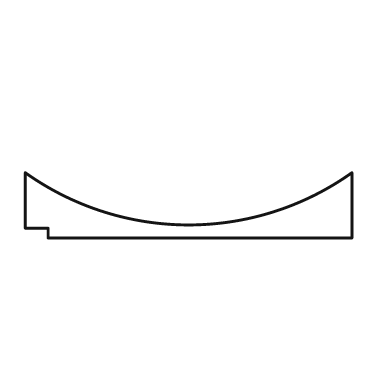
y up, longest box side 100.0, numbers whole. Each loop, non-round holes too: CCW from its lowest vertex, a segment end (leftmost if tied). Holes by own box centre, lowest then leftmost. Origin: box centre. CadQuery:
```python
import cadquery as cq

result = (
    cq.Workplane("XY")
    .moveTo(-43.0, -10.0)
    .lineTo(50.0, -10.0)
    .lineTo(50.0, 10.0)
    .threePointArc((0.0, -6.0), (-50.0, 10.0))
    .lineTo(-50.0, -7.0)
    .lineTo(-43.0, -7.0)
    .close()
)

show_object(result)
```